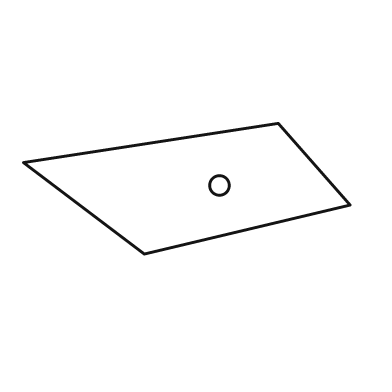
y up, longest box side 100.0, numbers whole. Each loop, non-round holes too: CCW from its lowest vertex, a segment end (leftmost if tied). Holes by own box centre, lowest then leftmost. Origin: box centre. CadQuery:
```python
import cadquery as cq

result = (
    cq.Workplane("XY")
    .moveTo(-13.0, -20.0)
    .lineTo(50.0, -5.0)
    .lineTo(28.0, 20.0)
    .lineTo(-50.0, 8.0)
    .close()
    .moveTo(10.0, 1.0)
    .circle(3.0)
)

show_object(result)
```